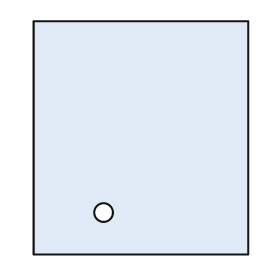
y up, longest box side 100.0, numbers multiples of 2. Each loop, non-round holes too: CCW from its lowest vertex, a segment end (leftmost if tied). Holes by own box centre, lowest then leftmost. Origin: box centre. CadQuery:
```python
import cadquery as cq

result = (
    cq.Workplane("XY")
    .moveTo(-46.0, -50.0)
    .lineTo(46.0, -50.0)
    .lineTo(46.0, 50.0)
    .lineTo(-46.0, 50.0)
    .close()
    .moveTo(-16.0, -32.0)
    .circle(4.0)
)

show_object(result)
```